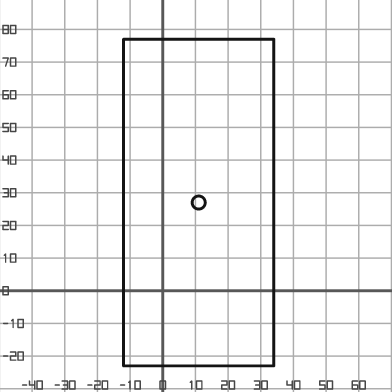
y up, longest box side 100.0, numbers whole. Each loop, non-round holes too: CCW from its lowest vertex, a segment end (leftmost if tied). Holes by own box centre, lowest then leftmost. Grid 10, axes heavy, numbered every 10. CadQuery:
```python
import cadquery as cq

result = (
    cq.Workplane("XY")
    .moveTo(-12.0, -23.0)
    .lineTo(34.0, -23.0)
    .lineTo(34.0, 77.0)
    .lineTo(-12.0, 77.0)
    .close()
    .moveTo(11.0, 27.0)
    .circle(2.0)
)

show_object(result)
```